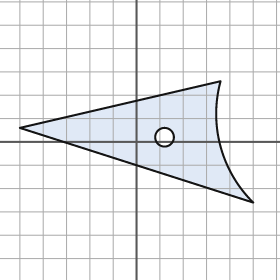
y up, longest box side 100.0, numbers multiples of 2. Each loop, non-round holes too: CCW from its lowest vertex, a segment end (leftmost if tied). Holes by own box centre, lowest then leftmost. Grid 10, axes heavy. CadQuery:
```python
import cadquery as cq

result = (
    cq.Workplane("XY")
    .moveTo(50.0, -26.0)
    .threePointArc((36.0, -2.0), (36.0, 26.0))
    .lineTo(-50.0, 6.0)
    .close()
    .moveTo(12.0, 2.0)
    .circle(4.0)
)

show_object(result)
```